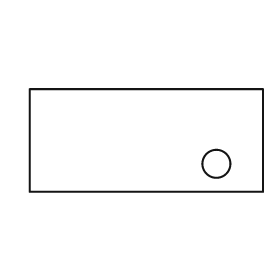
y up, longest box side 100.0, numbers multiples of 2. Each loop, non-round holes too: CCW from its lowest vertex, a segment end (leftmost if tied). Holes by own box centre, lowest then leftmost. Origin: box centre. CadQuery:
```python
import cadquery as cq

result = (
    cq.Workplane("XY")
    .moveTo(-50.0, -22.0)
    .lineTo(50.0, -22.0)
    .lineTo(50.0, 22.0)
    .lineTo(-50.0, 22.0)
    .close()
    .moveTo(30.0, -10.0)
    .circle(6.0)
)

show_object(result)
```